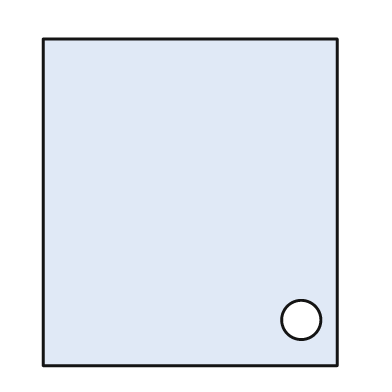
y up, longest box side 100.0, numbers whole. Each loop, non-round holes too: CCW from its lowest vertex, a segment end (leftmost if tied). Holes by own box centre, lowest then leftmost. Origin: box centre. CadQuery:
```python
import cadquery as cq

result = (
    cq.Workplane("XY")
    .moveTo(-45.0, -50.0)
    .lineTo(45.0, -50.0)
    .lineTo(45.0, 50.0)
    .lineTo(-45.0, 50.0)
    .close()
    .moveTo(34.0, -36.0)
    .circle(6.0)
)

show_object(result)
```